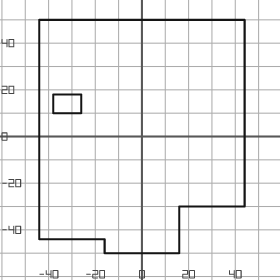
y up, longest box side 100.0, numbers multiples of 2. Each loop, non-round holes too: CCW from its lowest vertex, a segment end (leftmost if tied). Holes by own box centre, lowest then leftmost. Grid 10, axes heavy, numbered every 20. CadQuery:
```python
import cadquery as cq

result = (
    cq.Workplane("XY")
    .moveTo(-16.0, -50.0)
    .lineTo(16.0, -50.0)
    .lineTo(16.0, -30.0)
    .lineTo(44.0, -30.0)
    .lineTo(44.0, 50.0)
    .lineTo(-44.0, 50.0)
    .lineTo(-44.0, -44.0)
    .lineTo(-16.0, -44.0)
    .close()
    .moveTo(-38.0, 10.0)
    .lineTo(-26.0, 10.0)
    .lineTo(-26.0, 18.0)
    .lineTo(-38.0, 18.0)
    .close()
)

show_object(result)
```